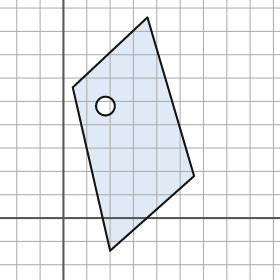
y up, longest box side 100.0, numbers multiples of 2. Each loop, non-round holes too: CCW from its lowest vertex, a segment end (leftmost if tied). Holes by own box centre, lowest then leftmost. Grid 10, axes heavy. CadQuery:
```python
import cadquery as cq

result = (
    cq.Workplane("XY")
    .moveTo(20.0, -14.0)
    .lineTo(56.0, 18.0)
    .lineTo(36.0, 86.0)
    .lineTo(4.0, 56.0)
    .close()
    .moveTo(18.0, 48.0)
    .circle(4.0)
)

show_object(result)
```